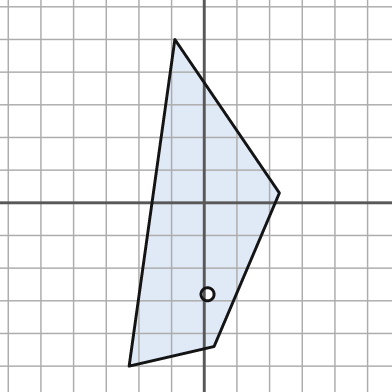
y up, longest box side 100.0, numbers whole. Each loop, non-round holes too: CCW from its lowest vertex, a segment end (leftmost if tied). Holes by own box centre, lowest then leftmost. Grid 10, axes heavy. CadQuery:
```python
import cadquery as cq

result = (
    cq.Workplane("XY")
    .moveTo(-23.0, -50.0)
    .lineTo(3.0, -44.0)
    .lineTo(23.0, 3.0)
    .lineTo(-9.0, 50.0)
    .close()
    .moveTo(1.0, -28.0)
    .circle(2.0)
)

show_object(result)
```